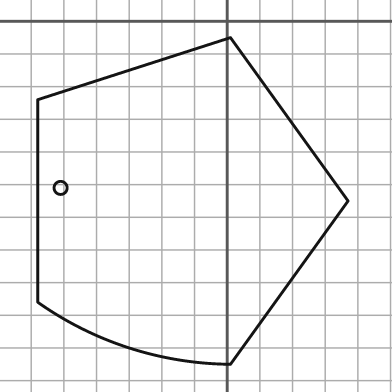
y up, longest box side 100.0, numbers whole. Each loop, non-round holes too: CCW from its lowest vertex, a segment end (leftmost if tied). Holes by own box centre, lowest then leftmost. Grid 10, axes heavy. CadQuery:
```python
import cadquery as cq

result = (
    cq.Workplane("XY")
    .moveTo(1.0, -105.0)
    .lineTo(37.0, -55.0)
    .lineTo(1.0, -5.0)
    .lineTo(-58.0, -24.0)
    .lineTo(-58.0, -86.0)
    .threePointArc((-30.0, -100.0), (1.0, -105.0))
    .close()
    .moveTo(-51.0, -51.0)
    .circle(2.0)
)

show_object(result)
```